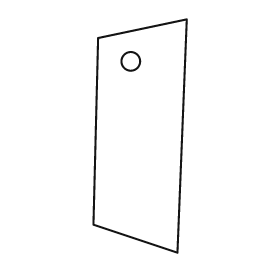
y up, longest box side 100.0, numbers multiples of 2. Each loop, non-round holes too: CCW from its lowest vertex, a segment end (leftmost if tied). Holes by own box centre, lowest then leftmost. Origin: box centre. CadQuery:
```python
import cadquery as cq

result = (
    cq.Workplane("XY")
    .moveTo(16.0, -50.0)
    .lineTo(20.0, 50.0)
    .lineTo(-18.0, 42.0)
    .lineTo(-20.0, -38.0)
    .close()
    .moveTo(-4.0, 32.0)
    .circle(4.0)
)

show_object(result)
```